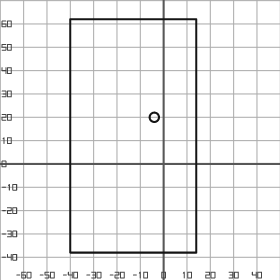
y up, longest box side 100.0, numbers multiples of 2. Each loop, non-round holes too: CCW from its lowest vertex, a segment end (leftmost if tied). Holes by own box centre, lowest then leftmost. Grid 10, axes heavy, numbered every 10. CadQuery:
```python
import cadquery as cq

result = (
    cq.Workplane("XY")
    .moveTo(-40.0, -38.0)
    .lineTo(14.0, -38.0)
    .lineTo(14.0, 62.0)
    .lineTo(-40.0, 62.0)
    .close()
    .moveTo(-4.0, 20.0)
    .circle(2.0)
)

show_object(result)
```